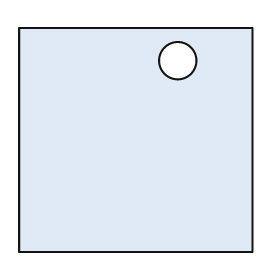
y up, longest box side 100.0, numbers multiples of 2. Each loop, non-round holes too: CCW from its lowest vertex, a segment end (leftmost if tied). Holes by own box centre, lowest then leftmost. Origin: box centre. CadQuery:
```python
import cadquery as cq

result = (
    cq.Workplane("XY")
    .moveTo(-50.0, -48.0)
    .lineTo(50.0, -48.0)
    .lineTo(50.0, 48.0)
    .lineTo(-50.0, 48.0)
    .close()
    .moveTo(18.0, 34.0)
    .circle(8.0)
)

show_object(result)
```